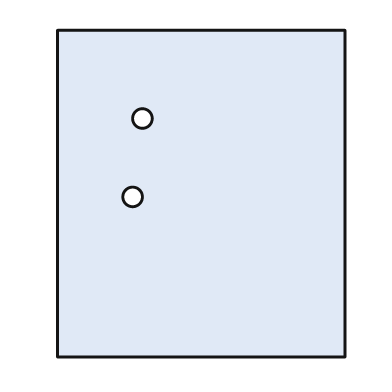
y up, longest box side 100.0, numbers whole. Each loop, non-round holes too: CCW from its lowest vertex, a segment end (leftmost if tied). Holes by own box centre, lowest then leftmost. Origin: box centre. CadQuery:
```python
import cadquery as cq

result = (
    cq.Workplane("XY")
    .moveTo(-44.0, -50.0)
    .lineTo(44.0, -50.0)
    .lineTo(44.0, 50.0)
    .lineTo(-44.0, 50.0)
    .close()
    .moveTo(-21.0, -1.0)
    .circle(3.0)
    .moveTo(-18.0, 23.0)
    .circle(3.0)
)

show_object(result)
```